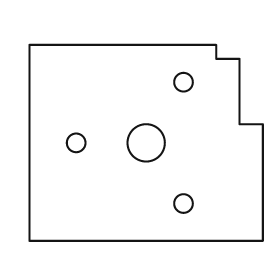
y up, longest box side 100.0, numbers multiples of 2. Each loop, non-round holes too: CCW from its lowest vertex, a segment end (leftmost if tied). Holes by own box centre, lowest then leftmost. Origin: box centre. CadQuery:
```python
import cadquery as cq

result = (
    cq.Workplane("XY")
    .moveTo(-50.0, -42.0)
    .lineTo(50.0, -42.0)
    .lineTo(50.0, 8.0)
    .lineTo(40.0, 8.0)
    .lineTo(40.0, 36.0)
    .lineTo(30.0, 36.0)
    .lineTo(30.0, 42.0)
    .lineTo(-50.0, 42.0)
    .close()
    .moveTo(16.0, -26.0)
    .circle(4.0)
    .moveTo(-30.0, 0.0)
    .circle(4.0)
    .moveTo(0.0, 0.0)
    .circle(8.0)
    .moveTo(16.0, 26.0)
    .circle(4.0)
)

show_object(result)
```